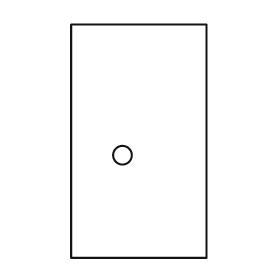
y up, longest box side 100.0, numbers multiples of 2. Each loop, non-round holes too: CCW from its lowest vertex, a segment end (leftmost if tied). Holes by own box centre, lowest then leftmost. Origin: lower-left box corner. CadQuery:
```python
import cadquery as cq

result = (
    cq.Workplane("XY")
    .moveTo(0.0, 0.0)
    .lineTo(58.0, 0.0)
    .lineTo(58.0, 100.0)
    .lineTo(0.0, 100.0)
    .close()
    .moveTo(22.0, 44.0)
    .circle(4.0)
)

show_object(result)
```